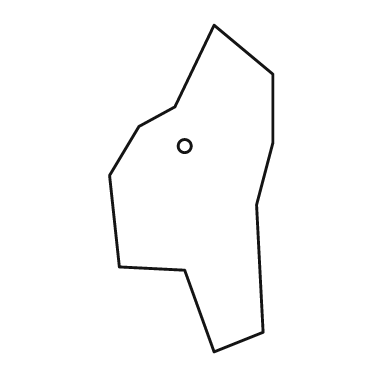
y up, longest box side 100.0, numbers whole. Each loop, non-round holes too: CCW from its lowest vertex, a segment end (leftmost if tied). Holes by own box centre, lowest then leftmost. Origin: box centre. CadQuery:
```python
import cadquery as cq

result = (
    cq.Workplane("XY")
    .moveTo(7.0, -50.0)
    .lineTo(22.0, -44.0)
    .lineTo(20.0, -5.0)
    .lineTo(25.0, 14.0)
    .lineTo(25.0, 35.0)
    .lineTo(7.0, 50.0)
    .lineTo(-5.0, 25.0)
    .lineTo(-16.0, 19.0)
    .lineTo(-25.0, 4.0)
    .lineTo(-22.0, -24.0)
    .lineTo(-2.0, -25.0)
    .close()
    .moveTo(-2.0, 13.0)
    .circle(2.0)
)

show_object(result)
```